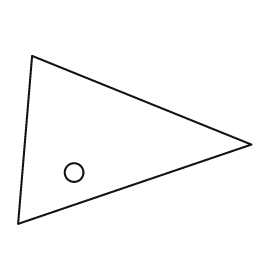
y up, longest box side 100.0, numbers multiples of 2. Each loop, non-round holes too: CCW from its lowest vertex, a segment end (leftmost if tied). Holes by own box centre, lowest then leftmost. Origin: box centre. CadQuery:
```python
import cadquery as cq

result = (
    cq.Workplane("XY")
    .moveTo(-50.0, -36.0)
    .lineTo(50.0, -2.0)
    .lineTo(-44.0, 36.0)
    .close()
    .moveTo(-26.0, -14.0)
    .circle(4.0)
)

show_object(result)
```